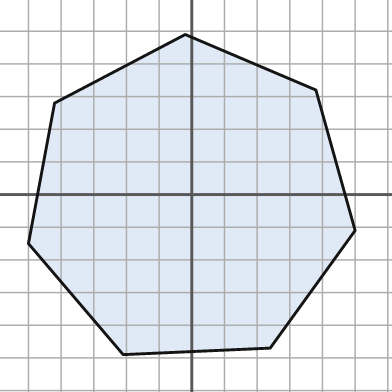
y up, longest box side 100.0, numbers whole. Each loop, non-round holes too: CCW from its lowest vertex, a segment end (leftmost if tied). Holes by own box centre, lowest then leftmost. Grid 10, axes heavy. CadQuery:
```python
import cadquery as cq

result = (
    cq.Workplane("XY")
    .moveTo(-21.0, -49.0)
    .lineTo(24.0, -47.0)
    .lineTo(50.0, -11.0)
    .lineTo(38.0, 32.0)
    .lineTo(-2.0, 49.0)
    .lineTo(-42.0, 28.0)
    .lineTo(-50.0, -15.0)
    .close()
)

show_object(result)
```